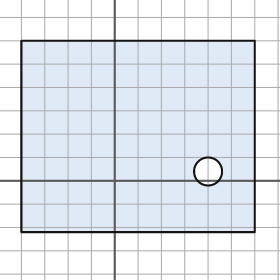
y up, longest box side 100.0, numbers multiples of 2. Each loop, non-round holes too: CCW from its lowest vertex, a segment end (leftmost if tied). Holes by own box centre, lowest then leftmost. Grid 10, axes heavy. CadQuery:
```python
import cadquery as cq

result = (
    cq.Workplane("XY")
    .moveTo(-40.0, -22.0)
    .lineTo(60.0, -22.0)
    .lineTo(60.0, 60.0)
    .lineTo(-40.0, 60.0)
    .close()
    .moveTo(40.0, 4.0)
    .circle(6.0)
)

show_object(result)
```